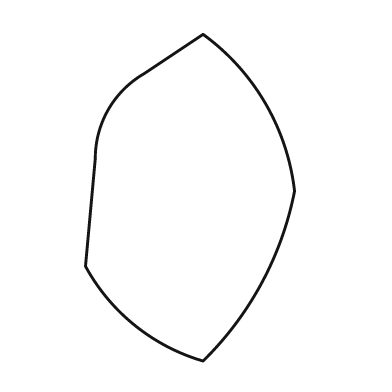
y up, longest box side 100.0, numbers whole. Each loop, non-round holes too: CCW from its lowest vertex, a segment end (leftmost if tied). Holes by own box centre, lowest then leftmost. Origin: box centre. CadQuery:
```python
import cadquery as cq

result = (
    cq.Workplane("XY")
    .moveTo(4.0, -50.0)
    .threePointArc((22.0, -26.0), (32.0, 2.0))
    .threePointArc((23.0, 29.0), (4.0, 50.0))
    .lineTo(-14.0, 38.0)
    .threePointArc((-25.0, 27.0), (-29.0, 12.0))
    .lineTo(-32.0, -21.0)
    .threePointArc((-17.0, -39.0), (4.0, -50.0))
    .close()
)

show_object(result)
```